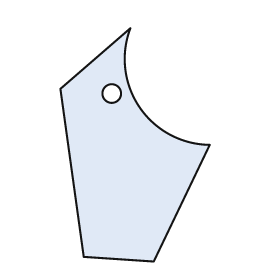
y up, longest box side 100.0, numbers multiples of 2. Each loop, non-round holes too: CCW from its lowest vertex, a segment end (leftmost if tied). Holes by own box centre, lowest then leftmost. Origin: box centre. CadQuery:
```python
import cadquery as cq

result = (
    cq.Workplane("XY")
    .moveTo(8.0, -50.0)
    .lineTo(32.0, 0.0)
    .threePointArc((2.0, 16.0), (-2.0, 50.0))
    .lineTo(-32.0, 24.0)
    .lineTo(-22.0, -48.0)
    .close()
    .moveTo(-10.0, 22.0)
    .circle(4.0)
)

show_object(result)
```